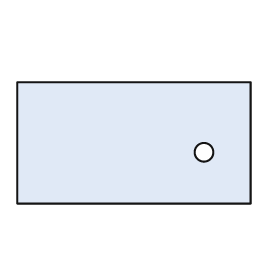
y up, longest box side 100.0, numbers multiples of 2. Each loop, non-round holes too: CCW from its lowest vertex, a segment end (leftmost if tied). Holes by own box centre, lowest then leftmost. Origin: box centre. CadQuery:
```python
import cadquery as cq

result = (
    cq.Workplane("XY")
    .moveTo(-50.0, -26.0)
    .lineTo(50.0, -26.0)
    .lineTo(50.0, 26.0)
    .lineTo(-50.0, 26.0)
    .close()
    .moveTo(30.0, -4.0)
    .circle(4.0)
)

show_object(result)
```